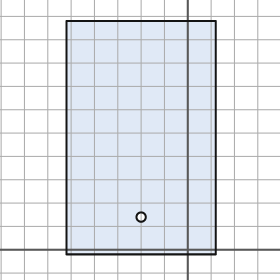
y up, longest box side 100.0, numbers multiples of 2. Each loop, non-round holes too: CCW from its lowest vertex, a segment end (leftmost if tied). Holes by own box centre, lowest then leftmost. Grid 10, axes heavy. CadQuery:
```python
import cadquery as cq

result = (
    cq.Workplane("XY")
    .moveTo(-52.0, -2.0)
    .lineTo(12.0, -2.0)
    .lineTo(12.0, 98.0)
    .lineTo(-52.0, 98.0)
    .close()
    .moveTo(-20.0, 14.0)
    .circle(2.0)
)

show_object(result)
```